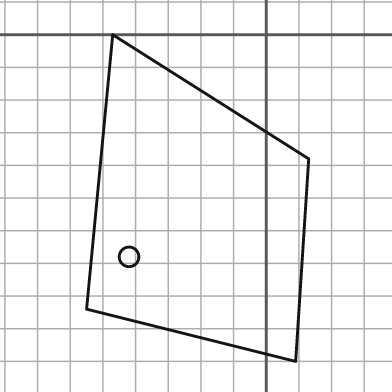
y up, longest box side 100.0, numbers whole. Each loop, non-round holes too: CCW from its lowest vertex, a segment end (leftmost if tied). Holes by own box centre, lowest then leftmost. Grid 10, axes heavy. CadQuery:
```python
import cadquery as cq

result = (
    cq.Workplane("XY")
    .moveTo(9.0, -100.0)
    .lineTo(13.0, -38.0)
    .lineTo(-47.0, 0.0)
    .lineTo(-55.0, -84.0)
    .close()
    .moveTo(-42.0, -68.0)
    .circle(3.0)
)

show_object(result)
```